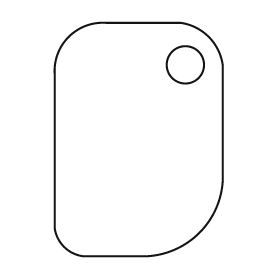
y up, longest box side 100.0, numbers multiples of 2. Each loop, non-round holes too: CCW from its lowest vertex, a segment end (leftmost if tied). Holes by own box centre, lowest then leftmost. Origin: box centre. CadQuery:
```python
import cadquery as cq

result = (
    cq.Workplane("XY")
    .moveTo(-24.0, -50.0)
    .lineTo(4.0, -50.0)
    .threePointArc((26.0, -40.0), (36.0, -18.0))
    .lineTo(36.0, 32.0)
    .threePointArc((30.0, 44.0), (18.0, 50.0))
    .lineTo(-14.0, 50.0)
    .threePointArc((-30.0, 44.0), (-36.0, 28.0))
    .lineTo(-36.0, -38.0)
    .threePointArc((-32.0, -46.0), (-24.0, -50.0))
    .close()
    .moveTo(20.0, 32.0)
    .circle(8.0)
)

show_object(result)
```